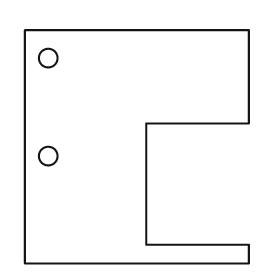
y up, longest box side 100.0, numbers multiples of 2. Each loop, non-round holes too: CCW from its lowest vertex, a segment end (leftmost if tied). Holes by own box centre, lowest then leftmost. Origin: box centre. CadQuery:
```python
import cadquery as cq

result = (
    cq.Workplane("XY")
    .moveTo(-48.0, -50.0)
    .lineTo(48.0, -50.0)
    .lineTo(48.0, -42.0)
    .lineTo(4.0, -42.0)
    .lineTo(4.0, 10.0)
    .lineTo(48.0, 10.0)
    .lineTo(48.0, 50.0)
    .lineTo(-48.0, 50.0)
    .close()
    .moveTo(-38.0, -4.0)
    .circle(4.0)
    .moveTo(-38.0, 38.0)
    .circle(4.0)
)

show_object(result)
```